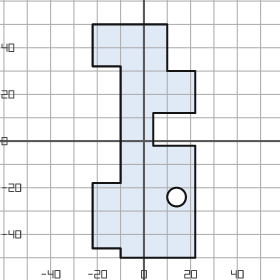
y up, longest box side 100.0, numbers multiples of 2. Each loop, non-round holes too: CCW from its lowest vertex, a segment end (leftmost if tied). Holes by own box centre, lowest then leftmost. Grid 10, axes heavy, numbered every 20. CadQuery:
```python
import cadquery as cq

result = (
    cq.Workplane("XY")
    .moveTo(-10.0, -50.0)
    .lineTo(22.0, -50.0)
    .lineTo(22.0, -2.0)
    .lineTo(4.0, -2.0)
    .lineTo(4.0, 12.0)
    .lineTo(22.0, 12.0)
    .lineTo(22.0, 30.0)
    .lineTo(10.0, 30.0)
    .lineTo(10.0, 50.0)
    .lineTo(-22.0, 50.0)
    .lineTo(-22.0, 32.0)
    .lineTo(-10.0, 32.0)
    .lineTo(-10.0, -18.0)
    .lineTo(-22.0, -18.0)
    .lineTo(-22.0, -46.0)
    .lineTo(-10.0, -46.0)
    .close()
    .moveTo(14.0, -24.0)
    .circle(4.0)
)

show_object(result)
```